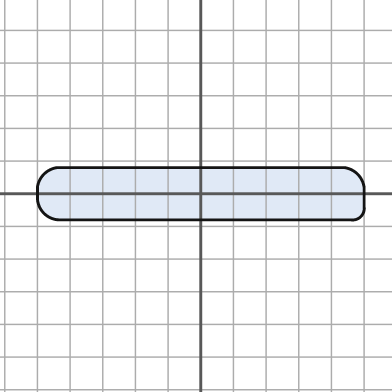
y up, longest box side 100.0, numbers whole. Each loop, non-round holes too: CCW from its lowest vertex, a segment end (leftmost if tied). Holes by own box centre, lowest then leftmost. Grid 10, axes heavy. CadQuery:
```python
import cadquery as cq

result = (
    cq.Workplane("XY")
    .moveTo(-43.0, -8.0)
    .lineTo(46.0, -8.0)
    .threePointArc((49.0, -7.0), (50.0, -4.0))
    .lineTo(50.0, 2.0)
    .threePointArc((48.0, 6.0), (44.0, 8.0))
    .lineTo(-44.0, 8.0)
    .threePointArc((-48.0, 6.0), (-50.0, 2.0))
    .lineTo(-50.0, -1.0)
    .threePointArc((-48.0, -6.0), (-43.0, -8.0))
    .close()
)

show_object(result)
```